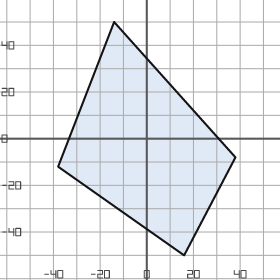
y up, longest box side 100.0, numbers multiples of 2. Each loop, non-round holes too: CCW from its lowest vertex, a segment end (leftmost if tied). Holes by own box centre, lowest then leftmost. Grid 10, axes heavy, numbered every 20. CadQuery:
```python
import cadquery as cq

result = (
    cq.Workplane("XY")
    .moveTo(16.0, -50.0)
    .lineTo(38.0, -8.0)
    .lineTo(-14.0, 50.0)
    .lineTo(-38.0, -12.0)
    .close()
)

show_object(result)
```